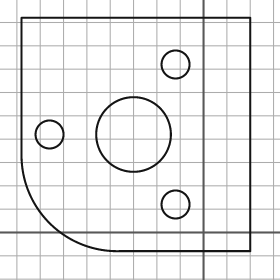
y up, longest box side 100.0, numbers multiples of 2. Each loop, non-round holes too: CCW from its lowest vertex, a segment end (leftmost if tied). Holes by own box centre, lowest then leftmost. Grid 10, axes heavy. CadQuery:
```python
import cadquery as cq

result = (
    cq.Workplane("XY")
    .moveTo(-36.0, -8.0)
    .lineTo(20.0, -8.0)
    .lineTo(20.0, 92.0)
    .lineTo(-78.0, 92.0)
    .lineTo(-78.0, 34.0)
    .threePointArc((-66.0, 4.0), (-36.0, -8.0))
    .close()
    .moveTo(-12.0, 12.0)
    .circle(6.0)
    .moveTo(-66.0, 42.0)
    .circle(6.0)
    .moveTo(-30.0, 42.0)
    .circle(16.0)
    .moveTo(-12.0, 72.0)
    .circle(6.0)
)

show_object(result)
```